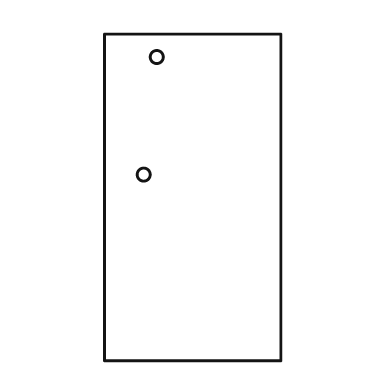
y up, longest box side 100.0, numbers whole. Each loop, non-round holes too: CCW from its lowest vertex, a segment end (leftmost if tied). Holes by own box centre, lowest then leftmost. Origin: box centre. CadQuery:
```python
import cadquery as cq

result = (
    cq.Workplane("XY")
    .moveTo(-27.0, -50.0)
    .lineTo(27.0, -50.0)
    .lineTo(27.0, 50.0)
    .lineTo(-27.0, 50.0)
    .close()
    .moveTo(-15.0, 7.0)
    .circle(2.0)
    .moveTo(-11.0, 43.0)
    .circle(2.0)
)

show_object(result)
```